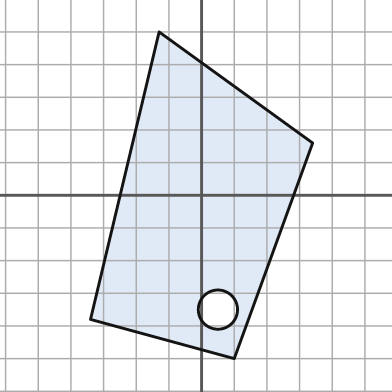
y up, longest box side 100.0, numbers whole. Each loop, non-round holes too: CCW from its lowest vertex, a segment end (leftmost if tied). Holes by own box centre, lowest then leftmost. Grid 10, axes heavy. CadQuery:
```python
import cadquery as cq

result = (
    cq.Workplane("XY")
    .moveTo(10.0, -50.0)
    .lineTo(34.0, 16.0)
    .lineTo(-13.0, 50.0)
    .lineTo(-34.0, -38.0)
    .close()
    .moveTo(5.0, -35.0)
    .circle(6.0)
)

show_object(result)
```